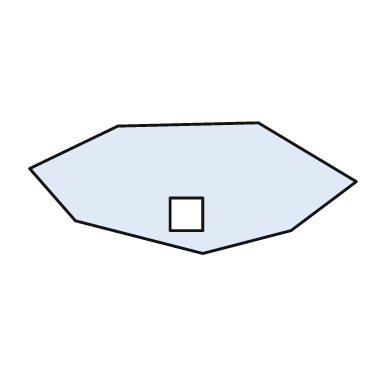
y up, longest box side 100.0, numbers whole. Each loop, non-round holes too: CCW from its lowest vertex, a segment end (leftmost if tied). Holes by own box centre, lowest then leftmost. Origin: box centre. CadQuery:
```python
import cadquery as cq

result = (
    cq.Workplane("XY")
    .moveTo(3.0, -20.0)
    .lineTo(30.0, -13.0)
    .lineTo(50.0, 2.0)
    .lineTo(20.0, 20.0)
    .lineTo(-23.0, 19.0)
    .lineTo(-50.0, 6.0)
    .lineTo(-36.0, -10.0)
    .close()
    .moveTo(-7.0, -13.0)
    .lineTo(3.0, -13.0)
    .lineTo(3.0, -3.0)
    .lineTo(-7.0, -3.0)
    .close()
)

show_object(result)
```